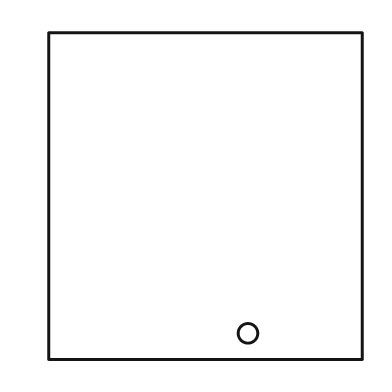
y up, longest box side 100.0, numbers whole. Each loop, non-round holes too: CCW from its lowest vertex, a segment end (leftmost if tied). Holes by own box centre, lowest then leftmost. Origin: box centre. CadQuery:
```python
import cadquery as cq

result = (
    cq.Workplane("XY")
    .moveTo(-48.0, -50.0)
    .lineTo(48.0, -50.0)
    .lineTo(48.0, 50.0)
    .lineTo(-48.0, 50.0)
    .close()
    .moveTo(13.0, -42.0)
    .circle(3.0)
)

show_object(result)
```